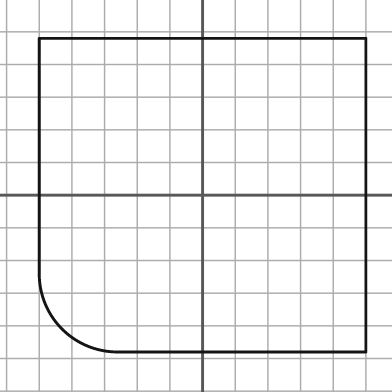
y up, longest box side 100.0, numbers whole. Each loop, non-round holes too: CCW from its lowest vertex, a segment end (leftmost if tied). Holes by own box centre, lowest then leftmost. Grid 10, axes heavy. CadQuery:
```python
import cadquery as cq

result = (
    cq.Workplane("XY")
    .moveTo(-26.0, -48.0)
    .lineTo(50.0, -48.0)
    .lineTo(50.0, 48.0)
    .lineTo(-50.0, 48.0)
    .lineTo(-50.0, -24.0)
    .threePointArc((-43.0, -41.0), (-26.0, -48.0))
    .close()
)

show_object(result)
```